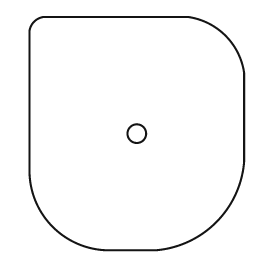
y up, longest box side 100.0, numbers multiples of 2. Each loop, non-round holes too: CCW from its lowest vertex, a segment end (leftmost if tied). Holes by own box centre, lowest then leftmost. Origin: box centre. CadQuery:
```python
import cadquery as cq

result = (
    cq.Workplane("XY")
    .moveTo(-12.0, -50.0)
    .lineTo(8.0, -50.0)
    .threePointArc((34.0, -38.0), (46.0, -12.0))
    .lineTo(46.0, 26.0)
    .threePointArc((38.0, 42.0), (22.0, 50.0))
    .lineTo(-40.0, 50.0)
    .threePointArc((-44.0, 48.0), (-46.0, 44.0))
    .lineTo(-46.0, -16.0)
    .threePointArc((-36.0, -40.0), (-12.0, -50.0))
    .close()
    .moveTo(0.0, 0.0)
    .circle(4.0)
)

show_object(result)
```